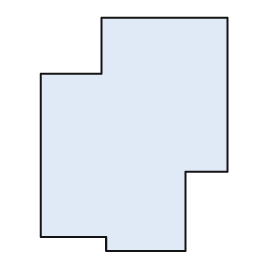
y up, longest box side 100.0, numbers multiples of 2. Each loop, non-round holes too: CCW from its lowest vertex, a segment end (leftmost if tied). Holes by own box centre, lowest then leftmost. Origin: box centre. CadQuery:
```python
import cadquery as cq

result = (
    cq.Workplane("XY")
    .moveTo(-12.0, -50.0)
    .lineTo(22.0, -50.0)
    .lineTo(22.0, -16.0)
    .lineTo(40.0, -16.0)
    .lineTo(40.0, 50.0)
    .lineTo(-14.0, 50.0)
    .lineTo(-14.0, 26.0)
    .lineTo(-40.0, 26.0)
    .lineTo(-40.0, -44.0)
    .lineTo(-12.0, -44.0)
    .close()
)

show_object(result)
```